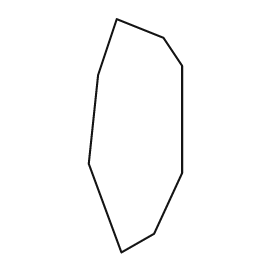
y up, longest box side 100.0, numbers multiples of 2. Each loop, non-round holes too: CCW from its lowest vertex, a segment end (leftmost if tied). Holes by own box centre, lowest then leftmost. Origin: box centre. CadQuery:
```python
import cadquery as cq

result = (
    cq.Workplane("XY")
    .moveTo(-6.0, -50.0)
    .lineTo(8.0, -42.0)
    .lineTo(20.0, -16.0)
    .lineTo(20.0, 30.0)
    .lineTo(12.0, 42.0)
    .lineTo(-8.0, 50.0)
    .lineTo(-16.0, 26.0)
    .lineTo(-20.0, -12.0)
    .close()
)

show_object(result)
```